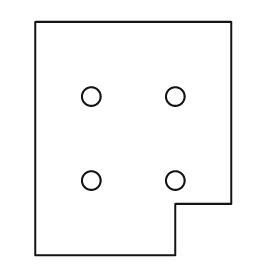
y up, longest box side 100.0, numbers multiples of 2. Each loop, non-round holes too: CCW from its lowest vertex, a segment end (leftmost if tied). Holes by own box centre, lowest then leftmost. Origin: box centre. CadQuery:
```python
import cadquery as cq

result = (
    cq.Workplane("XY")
    .moveTo(-42.0, -50.0)
    .lineTo(18.0, -50.0)
    .lineTo(18.0, -28.0)
    .lineTo(42.0, -28.0)
    .lineTo(42.0, 50.0)
    .lineTo(-42.0, 50.0)
    .close()
    .moveTo(-18.0, -18.0)
    .circle(4.0)
    .moveTo(18.0, -18.0)
    .circle(4.0)
    .moveTo(-18.0, 18.0)
    .circle(4.0)
    .moveTo(18.0, 18.0)
    .circle(4.0)
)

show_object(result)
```